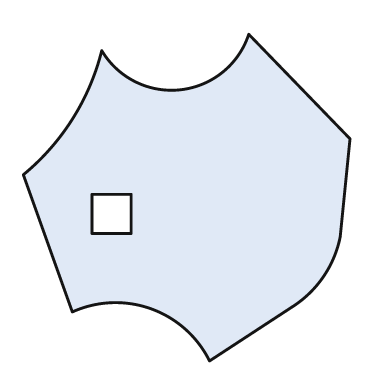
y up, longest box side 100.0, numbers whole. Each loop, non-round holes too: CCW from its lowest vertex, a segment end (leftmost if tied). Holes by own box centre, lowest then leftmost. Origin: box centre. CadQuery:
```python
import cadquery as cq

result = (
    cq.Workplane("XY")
    .moveTo(7.0, -50.0)
    .lineTo(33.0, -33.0)
    .threePointArc((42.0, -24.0), (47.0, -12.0))
    .lineTo(50.0, 18.0)
    .lineTo(19.0, 50.0)
    .threePointArc((-2.0, 33.0), (-26.0, 45.0))
    .threePointArc((-35.0, 24.0), (-50.0, 7.0))
    .lineTo(-35.0, -35.0)
    .threePointArc((-11.0, -34.0), (7.0, -50.0))
    .close()
    .moveTo(-29.0, -11.0)
    .lineTo(-17.0, -11.0)
    .lineTo(-17.0, 1.0)
    .lineTo(-29.0, 1.0)
    .close()
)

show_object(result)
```